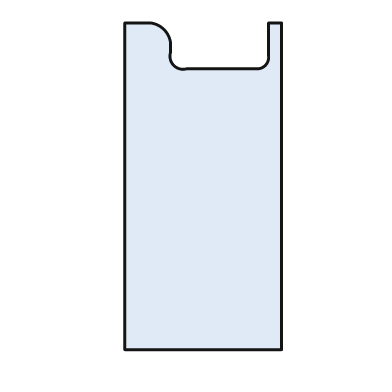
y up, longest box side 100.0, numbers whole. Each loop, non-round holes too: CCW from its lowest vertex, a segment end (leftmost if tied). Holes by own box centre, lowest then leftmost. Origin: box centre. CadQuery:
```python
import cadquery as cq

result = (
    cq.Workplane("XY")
    .moveTo(-24.0, -50.0)
    .lineTo(24.0, -50.0)
    .lineTo(24.0, 50.0)
    .lineTo(20.0, 50.0)
    .lineTo(20.0, 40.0)
    .threePointArc((19.0, 37.0), (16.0, 36.0))
    .lineTo(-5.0, 36.0)
    .threePointArc((-9.0, 37.0), (-10.0, 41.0))
    .lineTo(-10.0, 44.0)
    .threePointArc((-12.0, 48.0), (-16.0, 50.0))
    .lineTo(-24.0, 50.0)
    .close()
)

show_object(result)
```